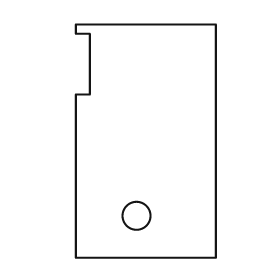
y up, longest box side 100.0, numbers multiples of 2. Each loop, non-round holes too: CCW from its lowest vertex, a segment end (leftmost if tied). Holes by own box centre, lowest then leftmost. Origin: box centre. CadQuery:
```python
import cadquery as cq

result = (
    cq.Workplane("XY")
    .moveTo(-30.0, -50.0)
    .lineTo(30.0, -50.0)
    .lineTo(30.0, 50.0)
    .lineTo(-30.0, 50.0)
    .lineTo(-30.0, 46.0)
    .lineTo(-24.0, 46.0)
    .lineTo(-24.0, 20.0)
    .lineTo(-30.0, 20.0)
    .close()
    .moveTo(-4.0, -32.0)
    .circle(6.0)
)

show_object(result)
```